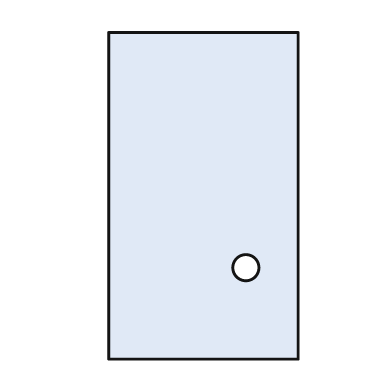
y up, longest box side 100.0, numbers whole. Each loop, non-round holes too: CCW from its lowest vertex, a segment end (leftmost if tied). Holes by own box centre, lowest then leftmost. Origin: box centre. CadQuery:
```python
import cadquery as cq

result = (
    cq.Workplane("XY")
    .moveTo(-29.0, -50.0)
    .lineTo(29.0, -50.0)
    .lineTo(29.0, 50.0)
    .lineTo(-29.0, 50.0)
    .close()
    .moveTo(13.0, -22.0)
    .circle(4.0)
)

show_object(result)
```